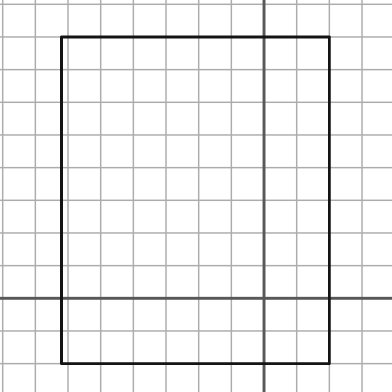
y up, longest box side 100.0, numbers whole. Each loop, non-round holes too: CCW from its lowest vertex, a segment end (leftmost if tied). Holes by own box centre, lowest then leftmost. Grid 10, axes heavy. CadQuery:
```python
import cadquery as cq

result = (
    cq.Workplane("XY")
    .moveTo(-62.0, -20.0)
    .lineTo(20.0, -20.0)
    .lineTo(20.0, 80.0)
    .lineTo(-62.0, 80.0)
    .close()
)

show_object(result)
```